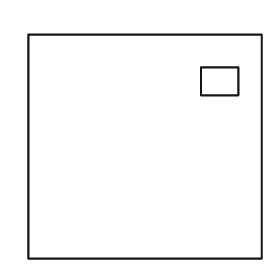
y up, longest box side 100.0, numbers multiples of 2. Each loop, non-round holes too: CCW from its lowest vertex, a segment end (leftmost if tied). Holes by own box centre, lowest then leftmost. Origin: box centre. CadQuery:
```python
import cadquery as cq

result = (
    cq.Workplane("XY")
    .moveTo(-50.0, -48.0)
    .lineTo(50.0, -48.0)
    .lineTo(50.0, 48.0)
    .lineTo(-50.0, 48.0)
    .close()
    .moveTo(24.0, 22.0)
    .lineTo(40.0, 22.0)
    .lineTo(40.0, 34.0)
    .lineTo(24.0, 34.0)
    .close()
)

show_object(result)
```